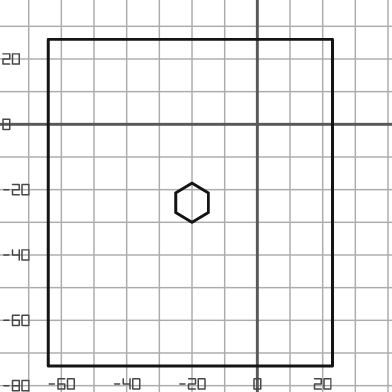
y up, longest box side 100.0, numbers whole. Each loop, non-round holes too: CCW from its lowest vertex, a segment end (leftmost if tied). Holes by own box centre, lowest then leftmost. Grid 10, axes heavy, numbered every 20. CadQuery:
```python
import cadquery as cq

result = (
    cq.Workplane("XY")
    .moveTo(-64.0, -74.0)
    .lineTo(23.0, -74.0)
    .lineTo(23.0, 26.0)
    .lineTo(-64.0, 26.0)
    .close()
    .moveTo(-20.0, -30.0)
    .lineTo(-15.0, -27.0)
    .lineTo(-15.0, -21.0)
    .lineTo(-20.0, -18.0)
    .lineTo(-25.0, -21.0)
    .lineTo(-25.0, -27.0)
    .close()
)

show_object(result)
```